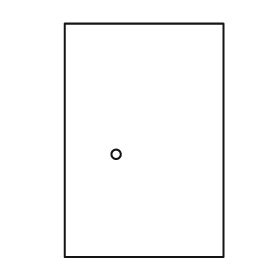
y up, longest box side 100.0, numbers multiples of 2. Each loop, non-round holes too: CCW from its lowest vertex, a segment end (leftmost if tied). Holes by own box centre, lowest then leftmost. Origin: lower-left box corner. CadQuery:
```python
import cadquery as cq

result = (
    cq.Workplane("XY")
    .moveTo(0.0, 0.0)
    .lineTo(68.0, 0.0)
    .lineTo(68.0, 100.0)
    .lineTo(0.0, 100.0)
    .close()
    .moveTo(22.0, 44.0)
    .circle(2.0)
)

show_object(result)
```